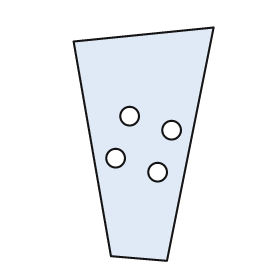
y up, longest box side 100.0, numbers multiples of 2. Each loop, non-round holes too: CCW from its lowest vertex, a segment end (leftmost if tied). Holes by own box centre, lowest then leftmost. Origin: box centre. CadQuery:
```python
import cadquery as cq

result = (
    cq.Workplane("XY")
    .moveTo(10.0, -50.0)
    .lineTo(30.0, 50.0)
    .lineTo(-30.0, 44.0)
    .lineTo(-14.0, -48.0)
    .close()
    .moveTo(6.0, -12.0)
    .circle(4.0)
    .moveTo(-12.0, -6.0)
    .circle(4.0)
    .moveTo(12.0, 6.0)
    .circle(4.0)
    .moveTo(-6.0, 12.0)
    .circle(4.0)
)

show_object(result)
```